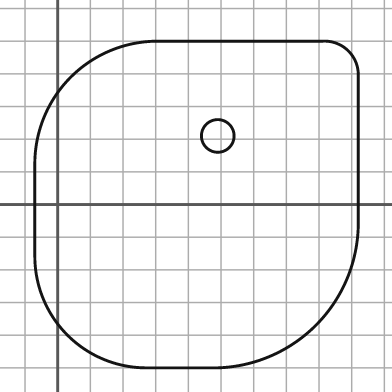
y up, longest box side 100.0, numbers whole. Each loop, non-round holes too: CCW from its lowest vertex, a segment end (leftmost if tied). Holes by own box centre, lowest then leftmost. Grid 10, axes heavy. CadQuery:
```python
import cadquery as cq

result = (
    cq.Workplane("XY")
    .moveTo(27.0, -50.0)
    .lineTo(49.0, -50.0)
    .threePointArc((79.0, -37.0), (92.0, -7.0))
    .lineTo(92.0, 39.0)
    .threePointArc((89.0, 47.0), (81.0, 50.0))
    .lineTo(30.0, 50.0)
    .threePointArc((4.0, 39.0), (-7.0, 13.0))
    .lineTo(-7.0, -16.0)
    .threePointArc((3.0, -40.0), (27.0, -50.0))
    .close()
    .moveTo(49.0, 21.0)
    .circle(5.0)
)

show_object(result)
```